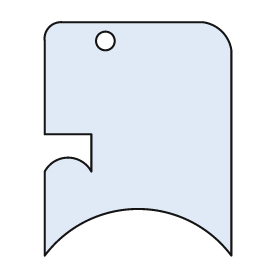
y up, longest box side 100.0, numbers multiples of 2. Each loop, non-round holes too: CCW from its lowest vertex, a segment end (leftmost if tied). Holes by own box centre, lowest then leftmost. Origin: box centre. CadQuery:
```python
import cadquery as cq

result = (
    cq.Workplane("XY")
    .moveTo(-40.0, -50.0)
    .threePointArc((0.0, -30.0), (40.0, -50.0))
    .lineTo(40.0, 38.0)
    .threePointArc((36.0, 46.0), (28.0, 50.0))
    .lineTo(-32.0, 50.0)
    .threePointArc((-38.0, 48.0), (-40.0, 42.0))
    .lineTo(-40.0, 2.0)
    .lineTo(-20.0, 2.0)
    .lineTo(-20.0, -14.0)
    .threePointArc((-30.0, -8.0), (-40.0, -14.0))
    .close()
    .moveTo(-14.0, 42.0)
    .circle(4.0)
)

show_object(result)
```